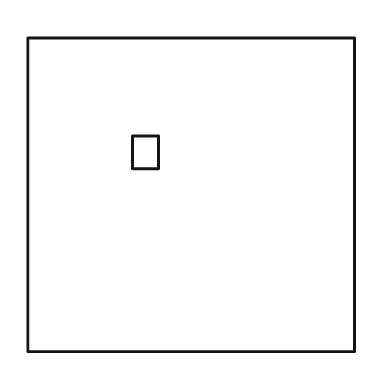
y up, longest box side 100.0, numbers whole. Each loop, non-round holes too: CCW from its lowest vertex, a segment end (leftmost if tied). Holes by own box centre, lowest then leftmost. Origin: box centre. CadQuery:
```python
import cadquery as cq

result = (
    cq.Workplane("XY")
    .moveTo(-50.0, -48.0)
    .lineTo(50.0, -48.0)
    .lineTo(50.0, 48.0)
    .lineTo(-50.0, 48.0)
    .close()
    .moveTo(-18.0, 8.0)
    .lineTo(-10.0, 8.0)
    .lineTo(-10.0, 18.0)
    .lineTo(-18.0, 18.0)
    .close()
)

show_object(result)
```